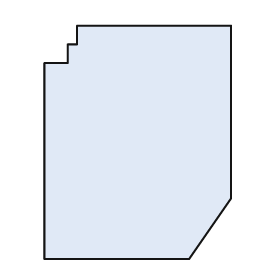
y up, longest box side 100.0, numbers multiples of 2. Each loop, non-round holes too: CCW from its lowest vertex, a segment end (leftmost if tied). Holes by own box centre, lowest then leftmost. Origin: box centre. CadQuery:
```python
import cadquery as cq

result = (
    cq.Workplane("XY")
    .moveTo(-40.0, -50.0)
    .lineTo(22.0, -50.0)
    .lineTo(40.0, -24.0)
    .lineTo(40.0, 50.0)
    .lineTo(-26.0, 50.0)
    .lineTo(-26.0, 42.0)
    .lineTo(-30.0, 42.0)
    .lineTo(-30.0, 34.0)
    .lineTo(-40.0, 34.0)
    .close()
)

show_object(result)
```